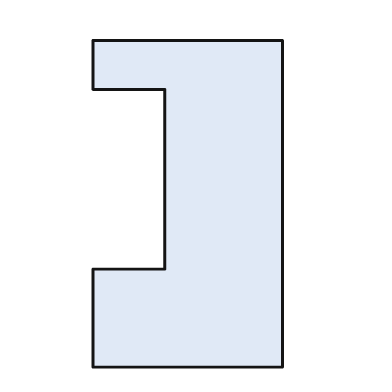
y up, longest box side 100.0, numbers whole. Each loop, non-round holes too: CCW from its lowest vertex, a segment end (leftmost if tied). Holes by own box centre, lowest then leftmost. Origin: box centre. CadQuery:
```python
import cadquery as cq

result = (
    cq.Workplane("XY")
    .moveTo(-29.0, -50.0)
    .lineTo(29.0, -50.0)
    .lineTo(29.0, 50.0)
    .lineTo(-29.0, 50.0)
    .lineTo(-29.0, 35.0)
    .lineTo(-7.0, 35.0)
    .lineTo(-7.0, -20.0)
    .lineTo(-29.0, -20.0)
    .close()
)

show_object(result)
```